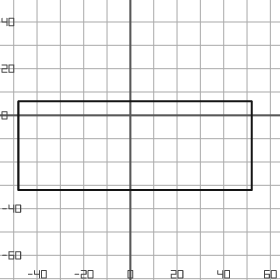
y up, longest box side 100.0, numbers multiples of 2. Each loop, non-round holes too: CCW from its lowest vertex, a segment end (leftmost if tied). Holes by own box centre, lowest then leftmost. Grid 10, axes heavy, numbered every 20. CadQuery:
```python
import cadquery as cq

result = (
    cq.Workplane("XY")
    .moveTo(-48.0, -32.0)
    .lineTo(52.0, -32.0)
    .lineTo(52.0, 6.0)
    .lineTo(-48.0, 6.0)
    .close()
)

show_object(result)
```